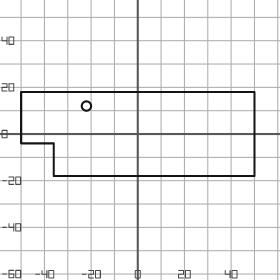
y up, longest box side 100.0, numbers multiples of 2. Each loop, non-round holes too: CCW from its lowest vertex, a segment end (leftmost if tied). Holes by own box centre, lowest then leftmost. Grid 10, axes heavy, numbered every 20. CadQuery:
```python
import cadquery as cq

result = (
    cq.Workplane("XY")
    .moveTo(-36.0, -18.0)
    .lineTo(50.0, -18.0)
    .lineTo(50.0, 18.0)
    .lineTo(-50.0, 18.0)
    .lineTo(-50.0, -4.0)
    .lineTo(-36.0, -4.0)
    .close()
    .moveTo(-22.0, 12.0)
    .circle(2.0)
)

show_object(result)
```